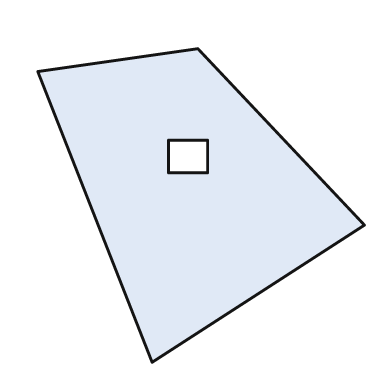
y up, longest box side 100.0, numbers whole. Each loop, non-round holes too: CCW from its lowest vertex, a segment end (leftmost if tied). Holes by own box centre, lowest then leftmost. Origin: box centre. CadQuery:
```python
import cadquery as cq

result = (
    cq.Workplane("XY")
    .moveTo(-15.0, -48.0)
    .lineTo(50.0, -6.0)
    .lineTo(-1.0, 48.0)
    .lineTo(-50.0, 41.0)
    .close()
    .moveTo(-10.0, 10.0)
    .lineTo(2.0, 10.0)
    .lineTo(2.0, 20.0)
    .lineTo(-10.0, 20.0)
    .close()
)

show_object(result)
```